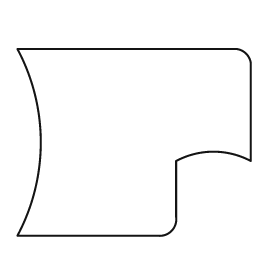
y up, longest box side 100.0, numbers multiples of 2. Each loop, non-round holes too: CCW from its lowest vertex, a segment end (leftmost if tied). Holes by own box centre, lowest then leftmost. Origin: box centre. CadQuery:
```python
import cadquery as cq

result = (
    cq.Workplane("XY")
    .moveTo(-50.0, -40.0)
    .lineTo(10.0, -40.0)
    .threePointArc((16.0, -38.0), (18.0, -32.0))
    .lineTo(18.0, -8.0)
    .threePointArc((34.0, -4.0), (50.0, -8.0))
    .lineTo(50.0, 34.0)
    .threePointArc((48.0, 38.0), (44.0, 40.0))
    .lineTo(-50.0, 40.0)
    .threePointArc((-40.0, 0.0), (-50.0, -40.0))
    .close()
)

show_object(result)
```